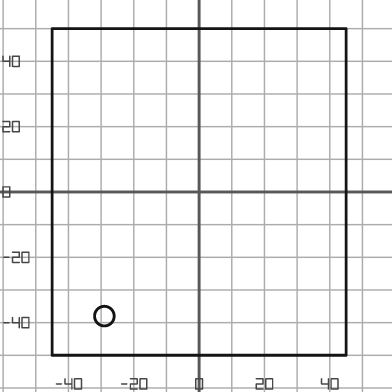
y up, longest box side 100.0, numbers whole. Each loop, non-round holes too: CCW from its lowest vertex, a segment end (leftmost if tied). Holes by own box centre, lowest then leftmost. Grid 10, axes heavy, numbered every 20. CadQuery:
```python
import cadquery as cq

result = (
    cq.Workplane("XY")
    .moveTo(-45.0, -50.0)
    .lineTo(45.0, -50.0)
    .lineTo(45.0, 50.0)
    .lineTo(-45.0, 50.0)
    .close()
    .moveTo(-29.0, -38.0)
    .circle(3.0)
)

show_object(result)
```